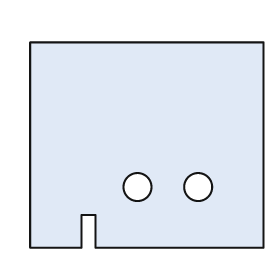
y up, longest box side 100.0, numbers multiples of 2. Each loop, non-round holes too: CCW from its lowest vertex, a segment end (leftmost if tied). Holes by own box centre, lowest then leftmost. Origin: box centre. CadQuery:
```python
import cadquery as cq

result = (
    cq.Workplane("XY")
    .moveTo(-50.0, -44.0)
    .lineTo(-28.0, -44.0)
    .lineTo(-28.0, -30.0)
    .lineTo(-22.0, -30.0)
    .lineTo(-22.0, -44.0)
    .lineTo(50.0, -44.0)
    .lineTo(50.0, 44.0)
    .lineTo(-50.0, 44.0)
    .close()
    .moveTo(-4.0, -18.0)
    .circle(6.0)
    .moveTo(22.0, -18.0)
    .circle(6.0)
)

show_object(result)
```